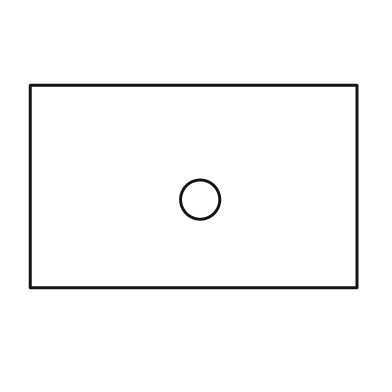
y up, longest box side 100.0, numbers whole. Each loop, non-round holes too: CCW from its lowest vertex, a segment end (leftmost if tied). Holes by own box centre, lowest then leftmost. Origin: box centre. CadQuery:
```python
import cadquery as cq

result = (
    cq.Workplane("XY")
    .moveTo(-50.0, -31.0)
    .lineTo(50.0, -31.0)
    .lineTo(50.0, 31.0)
    .lineTo(-50.0, 31.0)
    .close()
    .moveTo(2.0, -4.0)
    .circle(6.0)
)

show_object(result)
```